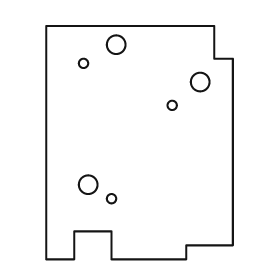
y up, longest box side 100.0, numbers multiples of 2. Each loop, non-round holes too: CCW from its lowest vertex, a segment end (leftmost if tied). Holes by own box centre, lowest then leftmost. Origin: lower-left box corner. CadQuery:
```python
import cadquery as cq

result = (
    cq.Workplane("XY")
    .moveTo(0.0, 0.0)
    .lineTo(12.0, 0.0)
    .lineTo(12.0, 12.0)
    .lineTo(28.0, 12.0)
    .lineTo(28.0, 0.0)
    .lineTo(60.0, 0.0)
    .lineTo(60.0, 6.0)
    .lineTo(80.0, 6.0)
    .lineTo(80.0, 86.0)
    .lineTo(72.0, 86.0)
    .lineTo(72.0, 100.0)
    .lineTo(0.0, 100.0)
    .close()
    .moveTo(28.0, 26.0)
    .circle(2.0)
    .moveTo(18.0, 32.0)
    .circle(4.0)
    .moveTo(54.0, 66.0)
    .circle(2.0)
    .moveTo(66.0, 76.0)
    .circle(4.0)
    .moveTo(16.0, 84.0)
    .circle(2.0)
    .moveTo(30.0, 92.0)
    .circle(4.0)
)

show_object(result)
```